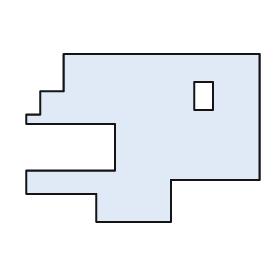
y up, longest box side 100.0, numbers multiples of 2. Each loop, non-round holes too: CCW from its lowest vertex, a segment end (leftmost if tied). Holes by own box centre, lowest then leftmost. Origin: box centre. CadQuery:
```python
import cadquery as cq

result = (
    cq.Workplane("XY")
    .moveTo(-20.0, -36.0)
    .lineTo(12.0, -36.0)
    .lineTo(12.0, -18.0)
    .lineTo(50.0, -18.0)
    .lineTo(50.0, 36.0)
    .lineTo(-34.0, 36.0)
    .lineTo(-34.0, 20.0)
    .lineTo(-44.0, 20.0)
    .lineTo(-44.0, 10.0)
    .lineTo(-50.0, 10.0)
    .lineTo(-50.0, 6.0)
    .lineTo(-12.0, 6.0)
    .lineTo(-12.0, -14.0)
    .lineTo(-50.0, -14.0)
    .lineTo(-50.0, -24.0)
    .lineTo(-20.0, -24.0)
    .close()
    .moveTo(22.0, 12.0)
    .lineTo(30.0, 12.0)
    .lineTo(30.0, 24.0)
    .lineTo(22.0, 24.0)
    .close()
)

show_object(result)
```